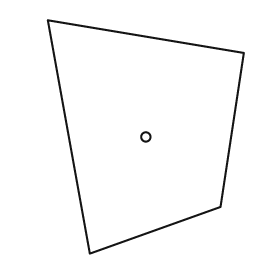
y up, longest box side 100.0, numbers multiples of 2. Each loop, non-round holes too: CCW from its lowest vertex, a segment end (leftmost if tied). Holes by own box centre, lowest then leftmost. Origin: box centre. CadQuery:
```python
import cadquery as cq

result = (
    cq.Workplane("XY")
    .moveTo(-24.0, -50.0)
    .lineTo(32.0, -30.0)
    .lineTo(42.0, 36.0)
    .lineTo(-42.0, 50.0)
    .close()
    .moveTo(0.0, 0.0)
    .circle(2.0)
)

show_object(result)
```